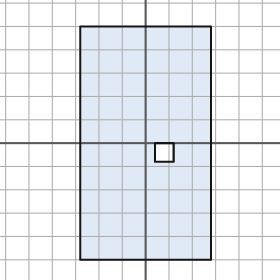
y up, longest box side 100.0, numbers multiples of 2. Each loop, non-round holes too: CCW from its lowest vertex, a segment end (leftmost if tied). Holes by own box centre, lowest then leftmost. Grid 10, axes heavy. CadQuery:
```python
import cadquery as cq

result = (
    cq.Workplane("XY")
    .moveTo(-28.0, -50.0)
    .lineTo(28.0, -50.0)
    .lineTo(28.0, 50.0)
    .lineTo(-28.0, 50.0)
    .close()
    .moveTo(4.0, -8.0)
    .lineTo(12.0, -8.0)
    .lineTo(12.0, 0.0)
    .lineTo(4.0, 0.0)
    .close()
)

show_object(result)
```